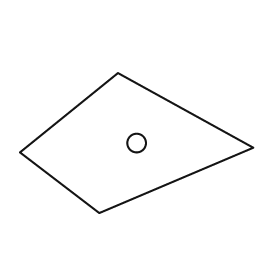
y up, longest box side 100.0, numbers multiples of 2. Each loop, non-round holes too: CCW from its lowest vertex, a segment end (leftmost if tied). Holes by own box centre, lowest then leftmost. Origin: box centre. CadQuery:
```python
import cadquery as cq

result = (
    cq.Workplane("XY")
    .moveTo(-16.0, -30.0)
    .lineTo(50.0, -2.0)
    .lineTo(-8.0, 30.0)
    .lineTo(-50.0, -4.0)
    .close()
    .moveTo(0.0, 0.0)
    .circle(4.0)
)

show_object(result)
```